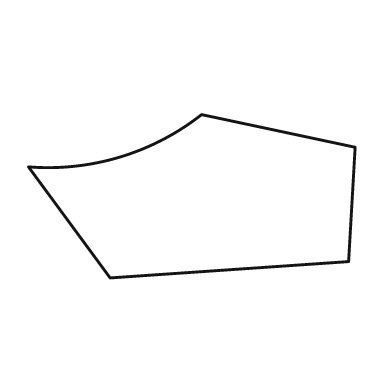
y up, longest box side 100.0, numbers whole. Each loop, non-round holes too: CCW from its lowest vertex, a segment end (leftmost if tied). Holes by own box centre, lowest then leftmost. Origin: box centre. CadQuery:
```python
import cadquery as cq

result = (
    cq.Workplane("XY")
    .moveTo(-25.0, -25.0)
    .lineTo(48.0, -20.0)
    .lineTo(50.0, 15.0)
    .lineTo(3.0, 25.0)
    .threePointArc((-22.0, 12.0), (-50.0, 9.0))
    .close()
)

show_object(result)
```